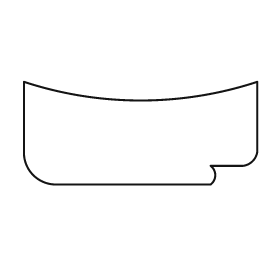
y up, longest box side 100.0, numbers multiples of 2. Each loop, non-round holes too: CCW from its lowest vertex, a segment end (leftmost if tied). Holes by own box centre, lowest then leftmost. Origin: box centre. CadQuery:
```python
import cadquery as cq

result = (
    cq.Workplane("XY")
    .moveTo(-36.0, -22.0)
    .lineTo(30.0, -22.0)
    .threePointArc((32.0, -18.0), (30.0, -14.0))
    .lineTo(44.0, -14.0)
    .threePointArc((48.0, -12.0), (50.0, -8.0))
    .lineTo(50.0, 22.0)
    .threePointArc((0.0, 14.0), (-50.0, 22.0))
    .lineTo(-50.0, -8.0)
    .threePointArc((-46.0, -18.0), (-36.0, -22.0))
    .close()
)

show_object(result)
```